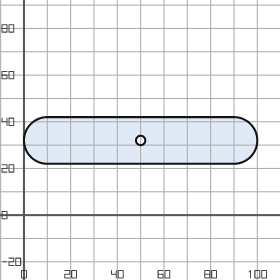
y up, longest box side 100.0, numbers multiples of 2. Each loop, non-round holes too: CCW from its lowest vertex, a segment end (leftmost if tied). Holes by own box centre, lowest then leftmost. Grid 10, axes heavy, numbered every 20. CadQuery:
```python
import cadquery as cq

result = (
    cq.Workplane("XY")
    .moveTo(10.0, 22.0)
    .lineTo(90.0, 22.0)
    .threePointArc((100.0, 32.0), (90.0, 42.0))
    .lineTo(10.0, 42.0)
    .threePointArc((0.0, 32.0), (10.0, 22.0))
    .close()
    .moveTo(50.0, 32.0)
    .circle(2.0)
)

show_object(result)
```